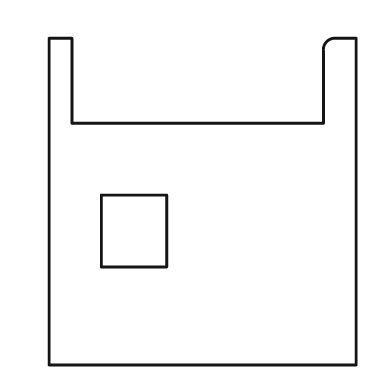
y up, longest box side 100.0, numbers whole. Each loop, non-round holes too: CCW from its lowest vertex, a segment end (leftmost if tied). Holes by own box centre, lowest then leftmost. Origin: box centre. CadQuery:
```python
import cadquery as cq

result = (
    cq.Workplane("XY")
    .moveTo(-47.0, -50.0)
    .lineTo(47.0, -50.0)
    .lineTo(47.0, 50.0)
    .lineTo(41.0, 50.0)
    .threePointArc((38.0, 49.0), (37.0, 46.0))
    .lineTo(37.0, 24.0)
    .lineTo(-40.0, 24.0)
    .lineTo(-40.0, 50.0)
    .lineTo(-47.0, 50.0)
    .close()
    .moveTo(-31.0, -20.0)
    .lineTo(-11.0, -20.0)
    .lineTo(-11.0, 2.0)
    .lineTo(-31.0, 2.0)
    .close()
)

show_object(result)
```